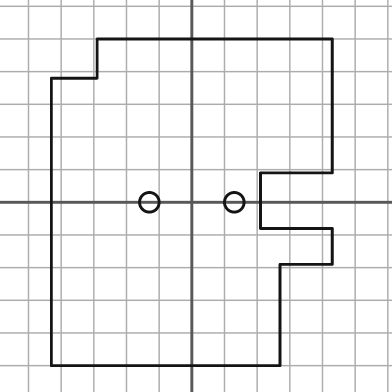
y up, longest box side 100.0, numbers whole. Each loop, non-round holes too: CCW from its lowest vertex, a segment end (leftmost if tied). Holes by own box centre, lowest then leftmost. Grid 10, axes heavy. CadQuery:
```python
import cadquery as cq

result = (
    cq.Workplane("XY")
    .moveTo(-43.0, -50.0)
    .lineTo(27.0, -50.0)
    .lineTo(27.0, -19.0)
    .lineTo(43.0, -19.0)
    .lineTo(43.0, -8.0)
    .lineTo(21.0, -8.0)
    .lineTo(21.0, 9.0)
    .lineTo(43.0, 9.0)
    .lineTo(43.0, 50.0)
    .lineTo(-29.0, 50.0)
    .lineTo(-29.0, 38.0)
    .lineTo(-43.0, 38.0)
    .close()
    .moveTo(-13.0, 0.0)
    .circle(3.0)
    .moveTo(13.0, 0.0)
    .circle(3.0)
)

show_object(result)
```